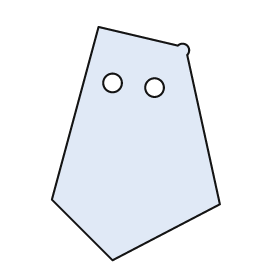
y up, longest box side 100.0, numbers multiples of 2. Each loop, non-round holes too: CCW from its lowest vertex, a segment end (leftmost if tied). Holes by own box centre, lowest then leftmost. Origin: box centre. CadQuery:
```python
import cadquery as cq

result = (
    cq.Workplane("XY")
    .moveTo(-10.0, -50.0)
    .lineTo(36.0, -26.0)
    .lineTo(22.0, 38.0)
    .threePointArc((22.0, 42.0), (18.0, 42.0))
    .lineTo(-16.0, 50.0)
    .lineTo(-36.0, -24.0)
    .close()
    .moveTo(8.0, 24.0)
    .circle(4.0)
    .moveTo(-10.0, 26.0)
    .circle(4.0)
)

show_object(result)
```